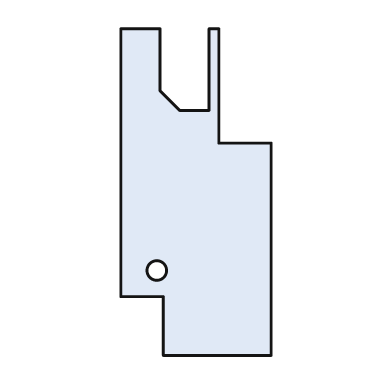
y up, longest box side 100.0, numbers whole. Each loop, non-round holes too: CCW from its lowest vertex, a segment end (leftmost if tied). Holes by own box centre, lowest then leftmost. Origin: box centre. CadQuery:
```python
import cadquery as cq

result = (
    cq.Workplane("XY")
    .moveTo(-10.0, -50.0)
    .lineTo(23.0, -50.0)
    .lineTo(23.0, 15.0)
    .lineTo(7.0, 15.0)
    .lineTo(7.0, 50.0)
    .lineTo(4.0, 50.0)
    .lineTo(4.0, 25.0)
    .lineTo(-5.0, 25.0)
    .lineTo(-11.0, 31.0)
    .lineTo(-11.0, 50.0)
    .lineTo(-23.0, 50.0)
    .lineTo(-23.0, -32.0)
    .lineTo(-10.0, -32.0)
    .close()
    .moveTo(-12.0, -24.0)
    .circle(3.0)
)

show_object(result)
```